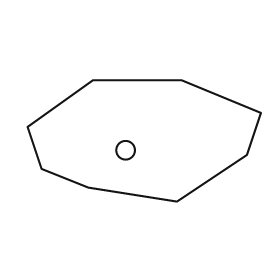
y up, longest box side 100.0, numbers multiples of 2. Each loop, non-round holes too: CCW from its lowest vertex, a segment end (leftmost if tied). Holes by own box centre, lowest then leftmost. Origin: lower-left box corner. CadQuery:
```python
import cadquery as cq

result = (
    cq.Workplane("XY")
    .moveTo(64.0, 0.0)
    .lineTo(94.0, 20.0)
    .lineTo(100.0, 38.0)
    .lineTo(66.0, 52.0)
    .lineTo(28.0, 52.0)
    .lineTo(0.0, 32.0)
    .lineTo(6.0, 14.0)
    .lineTo(26.0, 6.0)
    .close()
    .moveTo(42.0, 22.0)
    .circle(4.0)
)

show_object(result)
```